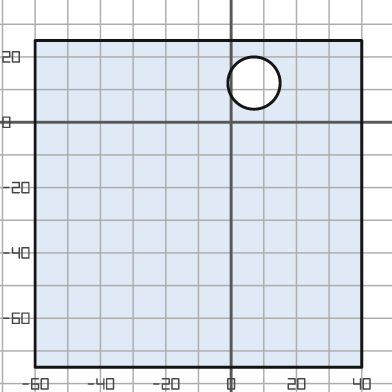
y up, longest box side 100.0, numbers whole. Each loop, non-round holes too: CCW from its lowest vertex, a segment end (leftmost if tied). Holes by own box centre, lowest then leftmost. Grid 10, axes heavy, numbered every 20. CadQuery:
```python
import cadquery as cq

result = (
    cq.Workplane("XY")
    .moveTo(-60.0, -75.0)
    .lineTo(40.0, -75.0)
    .lineTo(40.0, 25.0)
    .lineTo(-60.0, 25.0)
    .close()
    .moveTo(7.0, 12.0)
    .circle(8.0)
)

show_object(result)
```